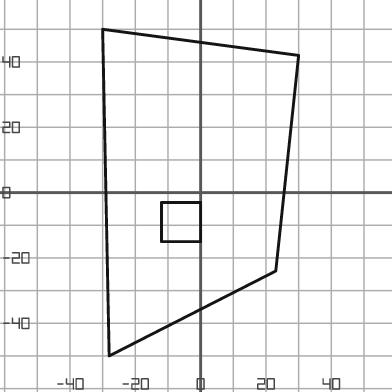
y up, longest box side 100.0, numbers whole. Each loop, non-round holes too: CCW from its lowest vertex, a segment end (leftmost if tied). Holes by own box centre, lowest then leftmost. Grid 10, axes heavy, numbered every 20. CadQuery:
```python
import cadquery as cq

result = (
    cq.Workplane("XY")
    .moveTo(-28.0, -50.0)
    .lineTo(23.0, -24.0)
    .lineTo(30.0, 42.0)
    .lineTo(-30.0, 50.0)
    .close()
    .moveTo(-12.0, -15.0)
    .lineTo(0.0, -15.0)
    .lineTo(0.0, -3.0)
    .lineTo(-12.0, -3.0)
    .close()
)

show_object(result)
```